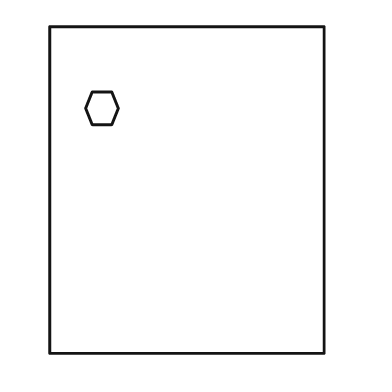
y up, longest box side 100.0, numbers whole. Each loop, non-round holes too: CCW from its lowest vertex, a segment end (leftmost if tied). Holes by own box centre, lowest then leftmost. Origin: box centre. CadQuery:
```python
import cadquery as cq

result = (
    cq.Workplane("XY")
    .moveTo(-42.0, -50.0)
    .lineTo(42.0, -50.0)
    .lineTo(42.0, 50.0)
    .lineTo(-42.0, 50.0)
    .close()
    .moveTo(-29.0, 20.0)
    .lineTo(-23.0, 20.0)
    .lineTo(-21.0, 25.0)
    .lineTo(-23.0, 30.0)
    .lineTo(-29.0, 30.0)
    .lineTo(-31.0, 25.0)
    .close()
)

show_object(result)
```